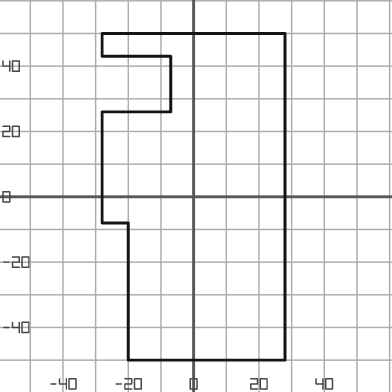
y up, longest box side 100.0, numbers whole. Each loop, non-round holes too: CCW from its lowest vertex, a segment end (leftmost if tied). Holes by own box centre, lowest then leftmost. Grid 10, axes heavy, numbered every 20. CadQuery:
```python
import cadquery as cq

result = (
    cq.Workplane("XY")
    .moveTo(-20.0, -50.0)
    .lineTo(28.0, -50.0)
    .lineTo(28.0, 50.0)
    .lineTo(-28.0, 50.0)
    .lineTo(-28.0, 43.0)
    .lineTo(-7.0, 43.0)
    .lineTo(-7.0, 26.0)
    .lineTo(-28.0, 26.0)
    .lineTo(-28.0, -8.0)
    .lineTo(-20.0, -8.0)
    .close()
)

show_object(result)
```